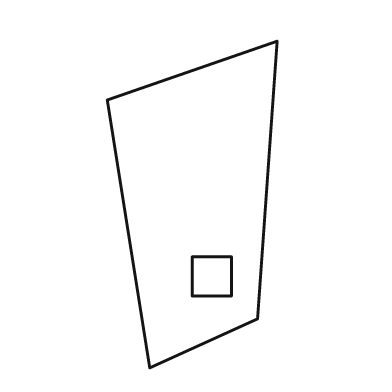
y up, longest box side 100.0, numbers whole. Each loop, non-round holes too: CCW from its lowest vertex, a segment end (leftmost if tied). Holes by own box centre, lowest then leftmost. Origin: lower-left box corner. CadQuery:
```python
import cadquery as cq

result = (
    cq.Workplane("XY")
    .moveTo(13.0, 0.0)
    .lineTo(46.0, 15.0)
    .lineTo(52.0, 100.0)
    .lineTo(0.0, 82.0)
    .close()
    .moveTo(26.0, 22.0)
    .lineTo(38.0, 22.0)
    .lineTo(38.0, 34.0)
    .lineTo(26.0, 34.0)
    .close()
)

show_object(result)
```